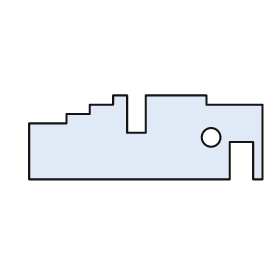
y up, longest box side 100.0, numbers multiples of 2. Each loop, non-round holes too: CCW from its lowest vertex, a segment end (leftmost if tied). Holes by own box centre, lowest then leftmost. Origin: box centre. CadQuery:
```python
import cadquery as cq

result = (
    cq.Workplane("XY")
    .moveTo(-50.0, -18.0)
    .lineTo(36.0, -18.0)
    .lineTo(36.0, -2.0)
    .lineTo(46.0, -2.0)
    .lineTo(46.0, -18.0)
    .lineTo(50.0, -18.0)
    .lineTo(50.0, 14.0)
    .lineTo(26.0, 14.0)
    .lineTo(26.0, 18.0)
    .lineTo(0.0, 18.0)
    .lineTo(0.0, 2.0)
    .lineTo(-8.0, 2.0)
    .lineTo(-8.0, 18.0)
    .lineTo(-14.0, 18.0)
    .lineTo(-14.0, 14.0)
    .lineTo(-24.0, 14.0)
    .lineTo(-24.0, 10.0)
    .lineTo(-34.0, 10.0)
    .lineTo(-34.0, 6.0)
    .lineTo(-50.0, 6.0)
    .close()
    .moveTo(28.0, 0.0)
    .circle(4.0)
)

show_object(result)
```